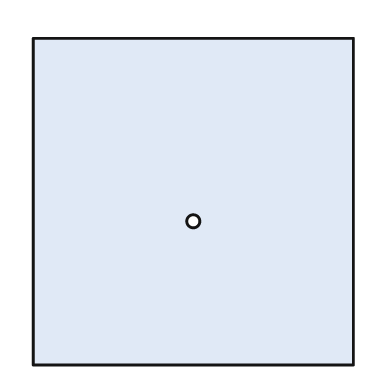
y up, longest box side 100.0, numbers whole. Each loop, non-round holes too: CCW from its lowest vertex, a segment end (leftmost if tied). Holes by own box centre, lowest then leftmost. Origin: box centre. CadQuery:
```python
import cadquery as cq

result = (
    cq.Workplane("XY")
    .moveTo(-49.0, -50.0)
    .lineTo(49.0, -50.0)
    .lineTo(49.0, 50.0)
    .lineTo(-49.0, 50.0)
    .close()
    .moveTo(0.0, -6.0)
    .circle(2.0)
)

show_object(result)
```